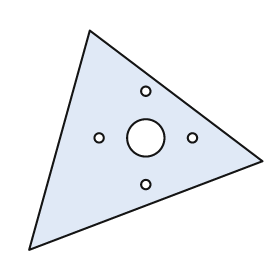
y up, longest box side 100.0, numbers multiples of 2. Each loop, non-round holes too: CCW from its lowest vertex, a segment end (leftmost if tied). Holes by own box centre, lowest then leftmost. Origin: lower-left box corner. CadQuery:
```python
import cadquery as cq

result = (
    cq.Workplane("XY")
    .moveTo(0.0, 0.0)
    .lineTo(100.0, 38.0)
    .lineTo(26.0, 94.0)
    .close()
    .moveTo(50.0, 28.0)
    .circle(2.0)
    .moveTo(30.0, 48.0)
    .circle(2.0)
    .moveTo(50.0, 48.0)
    .circle(8.0)
    .moveTo(70.0, 48.0)
    .circle(2.0)
    .moveTo(50.0, 68.0)
    .circle(2.0)
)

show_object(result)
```